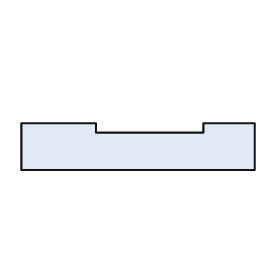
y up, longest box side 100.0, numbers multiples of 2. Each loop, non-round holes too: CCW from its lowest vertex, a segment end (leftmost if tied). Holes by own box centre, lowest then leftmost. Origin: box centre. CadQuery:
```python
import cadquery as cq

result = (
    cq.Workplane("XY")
    .moveTo(-50.0, -10.0)
    .lineTo(50.0, -10.0)
    .lineTo(50.0, 10.0)
    .lineTo(28.0, 10.0)
    .lineTo(28.0, 6.0)
    .lineTo(-18.0, 6.0)
    .lineTo(-18.0, 10.0)
    .lineTo(-50.0, 10.0)
    .close()
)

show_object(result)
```